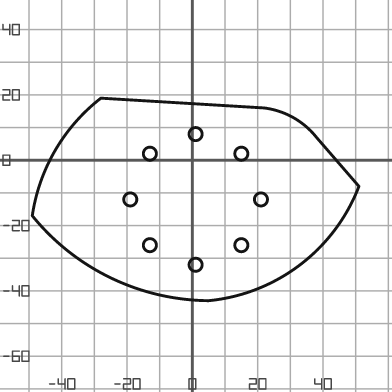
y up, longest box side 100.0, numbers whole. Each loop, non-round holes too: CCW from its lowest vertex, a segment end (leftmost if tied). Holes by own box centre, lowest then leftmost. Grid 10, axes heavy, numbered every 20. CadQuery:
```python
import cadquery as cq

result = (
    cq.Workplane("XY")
    .moveTo(5.0, -43.0)
    .threePointArc((33.0, -32.0), (51.0, -8.0))
    .lineTo(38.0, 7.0)
    .threePointArc((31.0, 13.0), (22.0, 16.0))
    .lineTo(-28.0, 19.0)
    .threePointArc((-42.0, 3.0), (-49.0, -17.0))
    .threePointArc((-25.0, -36.0), (5.0, -43.0))
    .close()
    .moveTo(1.0, -32.0)
    .circle(2.0)
    .moveTo(-13.0, -26.0)
    .circle(2.0)
    .moveTo(15.0, -26.0)
    .circle(2.0)
    .moveTo(-19.0, -12.0)
    .circle(2.0)
    .moveTo(21.0, -12.0)
    .circle(2.0)
    .moveTo(-13.0, 2.0)
    .circle(2.0)
    .moveTo(15.0, 2.0)
    .circle(2.0)
    .moveTo(1.0, 8.0)
    .circle(2.0)
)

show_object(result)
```